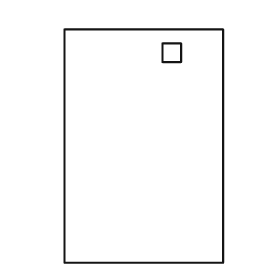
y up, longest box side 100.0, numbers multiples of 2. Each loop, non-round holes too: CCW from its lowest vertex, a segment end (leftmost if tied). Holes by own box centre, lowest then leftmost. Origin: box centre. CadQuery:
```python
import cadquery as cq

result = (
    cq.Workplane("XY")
    .moveTo(-34.0, -50.0)
    .lineTo(34.0, -50.0)
    .lineTo(34.0, 50.0)
    .lineTo(-34.0, 50.0)
    .close()
    .moveTo(8.0, 36.0)
    .lineTo(16.0, 36.0)
    .lineTo(16.0, 44.0)
    .lineTo(8.0, 44.0)
    .close()
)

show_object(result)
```